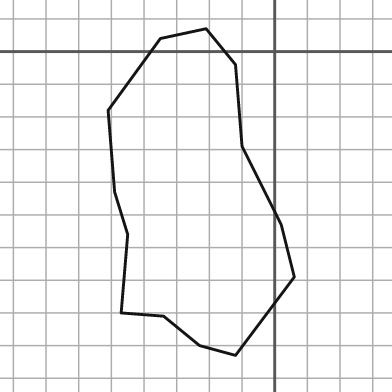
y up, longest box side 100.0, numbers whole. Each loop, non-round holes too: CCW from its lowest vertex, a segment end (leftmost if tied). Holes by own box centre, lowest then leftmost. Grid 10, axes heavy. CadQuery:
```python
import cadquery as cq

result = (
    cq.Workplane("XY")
    .moveTo(-12.0, -93.0)
    .lineTo(6.0, -69.0)
    .lineTo(2.0, -53.0)
    .lineTo(-10.0, -29.0)
    .lineTo(-12.0, -4.0)
    .lineTo(-21.0, 7.0)
    .lineTo(-35.0, 4.0)
    .lineTo(-51.0, -18.0)
    .lineTo(-49.0, -43.0)
    .lineTo(-45.0, -56.0)
    .lineTo(-47.0, -80.0)
    .lineTo(-34.0, -81.0)
    .lineTo(-23.0, -90.0)
    .close()
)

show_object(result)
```